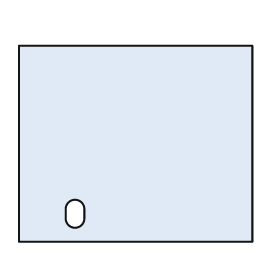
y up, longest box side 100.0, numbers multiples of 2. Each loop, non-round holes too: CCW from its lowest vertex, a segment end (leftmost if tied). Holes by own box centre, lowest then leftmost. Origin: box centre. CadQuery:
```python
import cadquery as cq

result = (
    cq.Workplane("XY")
    .moveTo(-50.0, -42.0)
    .lineTo(50.0, -42.0)
    .lineTo(50.0, 42.0)
    .lineTo(-50.0, 42.0)
    .close()
    .moveTo(-30.0, -32.0)
    .threePointArc((-26.0, -36.0), (-22.0, -32.0))
    .lineTo(-22.0, -28.0)
    .threePointArc((-26.0, -24.0), (-30.0, -28.0))
    .close()
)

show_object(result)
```